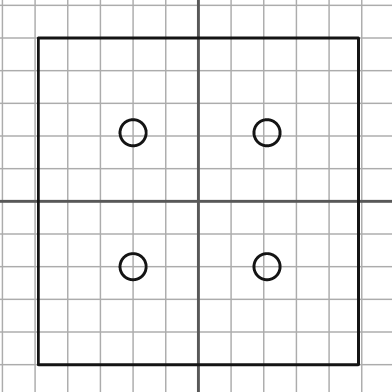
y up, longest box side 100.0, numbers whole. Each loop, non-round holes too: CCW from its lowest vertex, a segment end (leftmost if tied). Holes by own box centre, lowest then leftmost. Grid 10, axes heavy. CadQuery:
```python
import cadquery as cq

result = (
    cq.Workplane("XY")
    .moveTo(-49.0, -50.0)
    .lineTo(49.0, -50.0)
    .lineTo(49.0, 50.0)
    .lineTo(-49.0, 50.0)
    .close()
    .moveTo(-20.0, -20.0)
    .circle(4.0)
    .moveTo(21.0, -20.0)
    .circle(4.0)
    .moveTo(-20.0, 21.0)
    .circle(4.0)
    .moveTo(21.0, 21.0)
    .circle(4.0)
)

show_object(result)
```